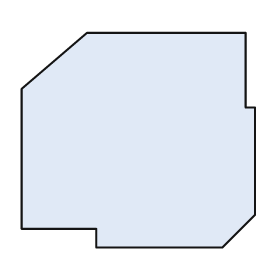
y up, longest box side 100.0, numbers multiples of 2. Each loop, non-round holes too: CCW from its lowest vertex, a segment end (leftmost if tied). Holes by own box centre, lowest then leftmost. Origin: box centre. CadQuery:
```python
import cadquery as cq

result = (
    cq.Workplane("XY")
    .moveTo(-18.0, -46.0)
    .lineTo(36.0, -46.0)
    .lineTo(50.0, -32.0)
    .lineTo(50.0, 14.0)
    .lineTo(46.0, 14.0)
    .lineTo(46.0, 46.0)
    .lineTo(-22.0, 46.0)
    .lineTo(-50.0, 22.0)
    .lineTo(-50.0, -38.0)
    .lineTo(-18.0, -38.0)
    .close()
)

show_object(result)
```